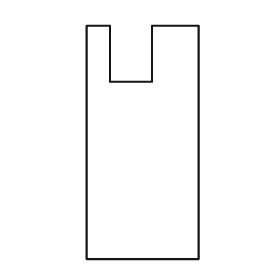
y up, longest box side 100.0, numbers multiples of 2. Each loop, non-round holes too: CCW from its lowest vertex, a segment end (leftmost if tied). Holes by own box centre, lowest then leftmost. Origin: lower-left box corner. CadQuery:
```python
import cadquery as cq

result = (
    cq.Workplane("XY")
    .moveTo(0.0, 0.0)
    .lineTo(48.0, 0.0)
    .lineTo(48.0, 100.0)
    .lineTo(28.0, 100.0)
    .lineTo(28.0, 76.0)
    .lineTo(10.0, 76.0)
    .lineTo(10.0, 100.0)
    .lineTo(0.0, 100.0)
    .close()
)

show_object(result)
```